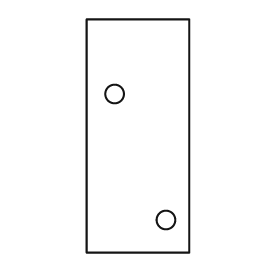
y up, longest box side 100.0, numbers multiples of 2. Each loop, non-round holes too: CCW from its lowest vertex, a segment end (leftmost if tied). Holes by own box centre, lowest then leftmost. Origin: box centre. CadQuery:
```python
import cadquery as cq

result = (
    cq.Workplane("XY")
    .moveTo(-22.0, -50.0)
    .lineTo(22.0, -50.0)
    .lineTo(22.0, 50.0)
    .lineTo(-22.0, 50.0)
    .close()
    .moveTo(12.0, -36.0)
    .circle(4.0)
    .moveTo(-10.0, 18.0)
    .circle(4.0)
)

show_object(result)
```